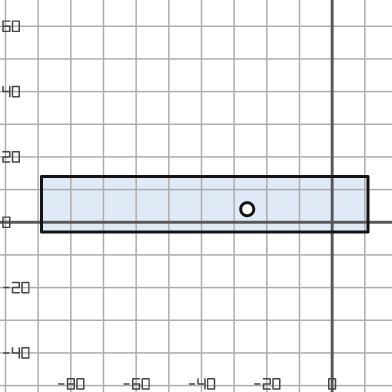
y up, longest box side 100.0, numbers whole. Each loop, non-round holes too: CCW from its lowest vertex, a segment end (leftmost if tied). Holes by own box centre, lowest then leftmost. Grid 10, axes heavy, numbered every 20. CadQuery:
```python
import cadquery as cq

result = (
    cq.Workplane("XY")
    .moveTo(-89.0, -3.0)
    .lineTo(11.0, -3.0)
    .lineTo(11.0, 14.0)
    .lineTo(-89.0, 14.0)
    .close()
    .moveTo(-26.0, 4.0)
    .circle(2.0)
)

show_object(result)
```